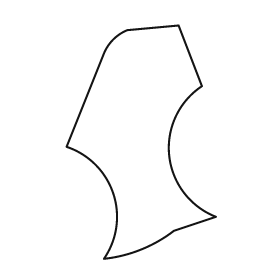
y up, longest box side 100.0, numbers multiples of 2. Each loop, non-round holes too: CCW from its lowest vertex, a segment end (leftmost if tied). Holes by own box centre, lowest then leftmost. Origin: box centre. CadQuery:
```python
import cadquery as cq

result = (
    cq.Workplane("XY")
    .moveTo(-16.0, -50.0)
    .threePointArc((0.0, -46.0), (14.0, -38.0))
    .lineTo(32.0, -32.0)
    .threePointArc((12.0, -6.0), (26.0, 24.0))
    .lineTo(16.0, 50.0)
    .lineTo(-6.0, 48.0)
    .threePointArc((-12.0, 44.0), (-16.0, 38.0))
    .lineTo(-32.0, -2.0)
    .threePointArc((-12.0, -22.0), (-16.0, -50.0))
    .close()
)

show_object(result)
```